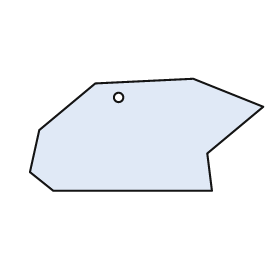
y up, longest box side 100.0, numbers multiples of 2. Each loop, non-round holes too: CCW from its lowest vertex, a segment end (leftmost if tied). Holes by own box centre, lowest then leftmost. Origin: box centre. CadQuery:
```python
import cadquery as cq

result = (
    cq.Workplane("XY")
    .moveTo(-40.0, -24.0)
    .lineTo(28.0, -24.0)
    .lineTo(26.0, -8.0)
    .lineTo(50.0, 12.0)
    .lineTo(20.0, 24.0)
    .lineTo(-22.0, 22.0)
    .lineTo(-46.0, 2.0)
    .lineTo(-50.0, -16.0)
    .close()
    .moveTo(-12.0, 16.0)
    .circle(2.0)
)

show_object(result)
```